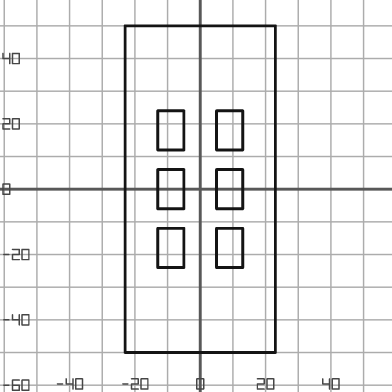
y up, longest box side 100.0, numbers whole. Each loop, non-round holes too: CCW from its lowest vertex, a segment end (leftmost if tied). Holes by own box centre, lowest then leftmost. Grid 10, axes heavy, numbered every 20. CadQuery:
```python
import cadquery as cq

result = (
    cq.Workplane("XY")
    .moveTo(-23.0, -50.0)
    .lineTo(23.0, -50.0)
    .lineTo(23.0, 50.0)
    .lineTo(-23.0, 50.0)
    .close()
    .moveTo(-13.0, -24.0)
    .lineTo(-5.0, -24.0)
    .lineTo(-5.0, -12.0)
    .lineTo(-13.0, -12.0)
    .close()
    .moveTo(5.0, -24.0)
    .lineTo(13.0, -24.0)
    .lineTo(13.0, -12.0)
    .lineTo(5.0, -12.0)
    .close()
    .moveTo(-13.0, -6.0)
    .lineTo(-5.0, -6.0)
    .lineTo(-5.0, 6.0)
    .lineTo(-13.0, 6.0)
    .close()
    .moveTo(5.0, -6.0)
    .lineTo(13.0, -6.0)
    .lineTo(13.0, 6.0)
    .lineTo(5.0, 6.0)
    .close()
    .moveTo(-13.0, 12.0)
    .lineTo(-5.0, 12.0)
    .lineTo(-5.0, 24.0)
    .lineTo(-13.0, 24.0)
    .close()
    .moveTo(5.0, 12.0)
    .lineTo(13.0, 12.0)
    .lineTo(13.0, 24.0)
    .lineTo(5.0, 24.0)
    .close()
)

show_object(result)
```